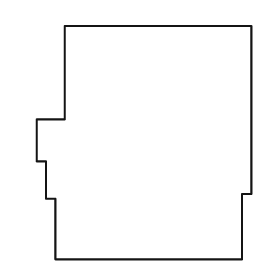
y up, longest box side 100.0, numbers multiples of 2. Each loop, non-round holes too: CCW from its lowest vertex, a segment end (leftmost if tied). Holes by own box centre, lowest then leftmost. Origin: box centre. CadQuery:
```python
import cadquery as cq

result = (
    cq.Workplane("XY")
    .moveTo(-38.0, -50.0)
    .lineTo(42.0, -50.0)
    .lineTo(42.0, -22.0)
    .lineTo(46.0, -22.0)
    .lineTo(46.0, 50.0)
    .lineTo(-34.0, 50.0)
    .lineTo(-34.0, 10.0)
    .lineTo(-46.0, 10.0)
    .lineTo(-46.0, -8.0)
    .lineTo(-42.0, -8.0)
    .lineTo(-42.0, -24.0)
    .lineTo(-38.0, -24.0)
    .close()
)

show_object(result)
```